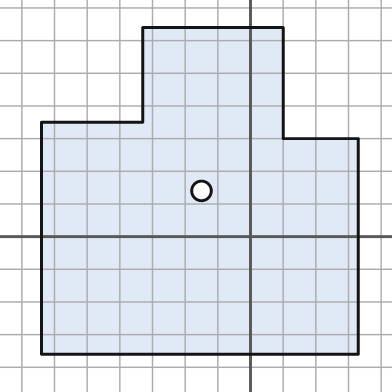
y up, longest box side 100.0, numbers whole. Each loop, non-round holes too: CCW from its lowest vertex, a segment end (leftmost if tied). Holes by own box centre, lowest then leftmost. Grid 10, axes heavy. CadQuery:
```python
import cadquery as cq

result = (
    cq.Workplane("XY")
    .moveTo(-64.0, -36.0)
    .lineTo(33.0, -36.0)
    .lineTo(33.0, 30.0)
    .lineTo(10.0, 30.0)
    .lineTo(10.0, 64.0)
    .lineTo(-33.0, 64.0)
    .lineTo(-33.0, 35.0)
    .lineTo(-64.0, 35.0)
    .close()
    .moveTo(-15.0, 14.0)
    .circle(3.0)
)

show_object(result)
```